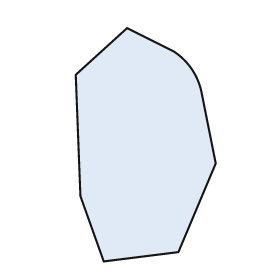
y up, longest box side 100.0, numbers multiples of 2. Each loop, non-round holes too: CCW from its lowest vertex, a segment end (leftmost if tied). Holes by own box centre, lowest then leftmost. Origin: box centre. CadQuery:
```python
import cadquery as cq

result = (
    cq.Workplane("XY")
    .moveTo(-18.0, -50.0)
    .lineTo(14.0, -46.0)
    .lineTo(30.0, -8.0)
    .lineTo(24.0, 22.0)
    .threePointArc((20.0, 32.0), (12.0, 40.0))
    .lineTo(-8.0, 50.0)
    .lineTo(-30.0, 30.0)
    .lineTo(-28.0, -22.0)
    .close()
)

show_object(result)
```